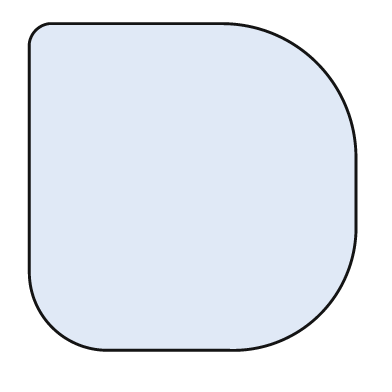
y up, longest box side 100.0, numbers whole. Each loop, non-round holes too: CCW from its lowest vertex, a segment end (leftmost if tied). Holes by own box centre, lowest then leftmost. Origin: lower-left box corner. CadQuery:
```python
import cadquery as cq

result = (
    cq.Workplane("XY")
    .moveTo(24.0, 0.0)
    .lineTo(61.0, 0.0)
    .threePointArc((89.0, 11.0), (100.0, 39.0))
    .lineTo(100.0, 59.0)
    .threePointArc((88.0, 88.0), (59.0, 100.0))
    .lineTo(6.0, 100.0)
    .threePointArc((2.0, 98.0), (0.0, 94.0))
    .lineTo(0.0, 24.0)
    .threePointArc((7.0, 7.0), (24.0, 0.0))
    .close()
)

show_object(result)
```